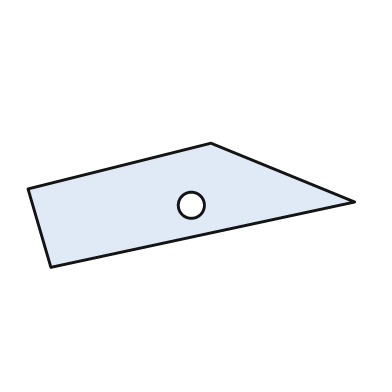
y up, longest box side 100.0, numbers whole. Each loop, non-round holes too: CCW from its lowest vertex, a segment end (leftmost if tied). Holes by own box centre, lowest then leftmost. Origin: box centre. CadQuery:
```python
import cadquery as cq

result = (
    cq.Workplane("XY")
    .moveTo(-43.0, -19.0)
    .lineTo(50.0, 1.0)
    .lineTo(6.0, 19.0)
    .lineTo(-50.0, 5.0)
    .close()
    .moveTo(0.0, 0.0)
    .circle(4.0)
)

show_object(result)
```